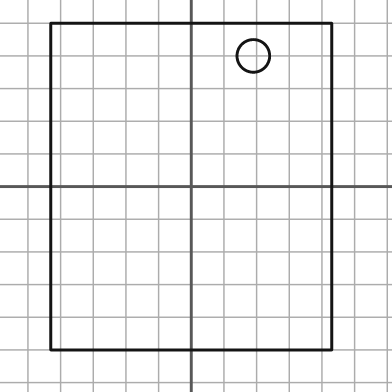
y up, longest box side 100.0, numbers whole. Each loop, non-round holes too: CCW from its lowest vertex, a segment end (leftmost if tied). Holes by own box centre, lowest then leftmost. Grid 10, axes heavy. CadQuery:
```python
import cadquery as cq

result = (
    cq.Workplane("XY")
    .moveTo(-43.0, -50.0)
    .lineTo(43.0, -50.0)
    .lineTo(43.0, 50.0)
    .lineTo(-43.0, 50.0)
    .close()
    .moveTo(19.0, 40.0)
    .circle(5.0)
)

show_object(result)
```